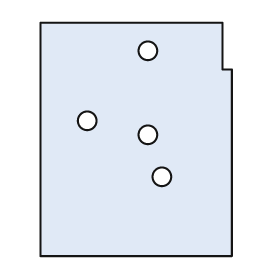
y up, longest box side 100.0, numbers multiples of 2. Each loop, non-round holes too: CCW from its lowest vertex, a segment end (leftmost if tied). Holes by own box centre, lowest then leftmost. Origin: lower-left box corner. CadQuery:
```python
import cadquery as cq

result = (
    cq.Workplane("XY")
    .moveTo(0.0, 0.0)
    .lineTo(82.0, 0.0)
    .lineTo(82.0, 80.0)
    .lineTo(78.0, 80.0)
    .lineTo(78.0, 100.0)
    .lineTo(0.0, 100.0)
    .close()
    .moveTo(52.0, 34.0)
    .circle(4.0)
    .moveTo(46.0, 52.0)
    .circle(4.0)
    .moveTo(20.0, 58.0)
    .circle(4.0)
    .moveTo(46.0, 88.0)
    .circle(4.0)
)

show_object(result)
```